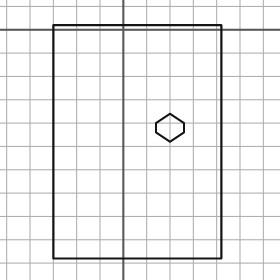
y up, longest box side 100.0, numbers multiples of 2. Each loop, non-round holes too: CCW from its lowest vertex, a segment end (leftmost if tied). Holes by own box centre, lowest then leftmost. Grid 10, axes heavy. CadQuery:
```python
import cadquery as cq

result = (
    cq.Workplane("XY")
    .moveTo(-30.0, -98.0)
    .lineTo(42.0, -98.0)
    .lineTo(42.0, 2.0)
    .lineTo(-30.0, 2.0)
    .close()
    .moveTo(20.0, -48.0)
    .lineTo(26.0, -44.0)
    .lineTo(26.0, -40.0)
    .lineTo(20.0, -36.0)
    .lineTo(14.0, -40.0)
    .lineTo(14.0, -44.0)
    .close()
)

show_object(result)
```